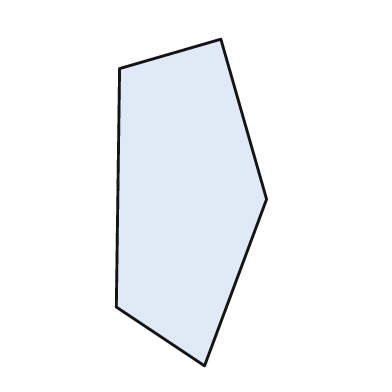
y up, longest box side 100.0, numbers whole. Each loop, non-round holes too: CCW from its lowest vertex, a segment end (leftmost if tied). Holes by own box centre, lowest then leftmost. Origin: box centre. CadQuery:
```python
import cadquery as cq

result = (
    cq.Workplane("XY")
    .moveTo(4.0, -50.0)
    .lineTo(23.0, 1.0)
    .lineTo(9.0, 50.0)
    .lineTo(-22.0, 41.0)
    .lineTo(-23.0, -32.0)
    .close()
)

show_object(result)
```